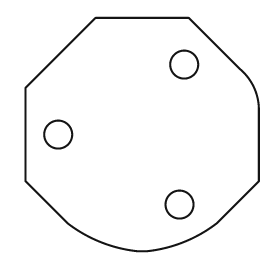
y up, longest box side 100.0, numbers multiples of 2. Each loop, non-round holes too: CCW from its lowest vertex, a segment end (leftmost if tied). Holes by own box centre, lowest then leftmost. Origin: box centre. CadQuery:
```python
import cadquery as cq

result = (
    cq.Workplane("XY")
    .moveTo(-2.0, -50.0)
    .lineTo(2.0, -50.0)
    .threePointArc((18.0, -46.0), (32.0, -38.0))
    .lineTo(50.0, -20.0)
    .lineTo(50.0, 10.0)
    .threePointArc((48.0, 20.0), (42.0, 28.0))
    .lineTo(20.0, 50.0)
    .lineTo(-20.0, 50.0)
    .lineTo(-50.0, 20.0)
    .lineTo(-50.0, -20.0)
    .lineTo(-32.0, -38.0)
    .threePointArc((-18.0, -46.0), (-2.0, -50.0))
    .close()
    .moveTo(16.0, -30.0)
    .circle(6.0)
    .moveTo(-36.0, 0.0)
    .circle(6.0)
    .moveTo(18.0, 30.0)
    .circle(6.0)
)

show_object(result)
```